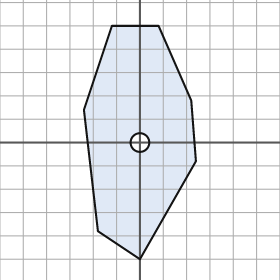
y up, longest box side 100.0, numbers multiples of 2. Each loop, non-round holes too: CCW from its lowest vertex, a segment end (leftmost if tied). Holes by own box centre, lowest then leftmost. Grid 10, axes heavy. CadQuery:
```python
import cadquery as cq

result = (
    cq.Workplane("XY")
    .moveTo(0.0, -50.0)
    .lineTo(24.0, -8.0)
    .lineTo(22.0, 18.0)
    .lineTo(8.0, 50.0)
    .lineTo(-12.0, 50.0)
    .lineTo(-24.0, 14.0)
    .lineTo(-18.0, -38.0)
    .close()
    .moveTo(0.0, 0.0)
    .circle(4.0)
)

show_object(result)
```